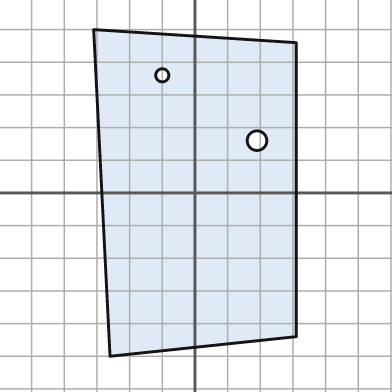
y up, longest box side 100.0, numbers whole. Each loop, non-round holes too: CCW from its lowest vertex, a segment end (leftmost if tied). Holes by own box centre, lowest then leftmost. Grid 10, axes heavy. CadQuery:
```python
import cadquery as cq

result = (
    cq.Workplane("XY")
    .moveTo(-26.0, -50.0)
    .lineTo(31.0, -44.0)
    .lineTo(31.0, 46.0)
    .lineTo(-31.0, 50.0)
    .close()
    .moveTo(19.0, 16.0)
    .circle(3.0)
    .moveTo(-10.0, 36.0)
    .circle(2.0)
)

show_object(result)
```